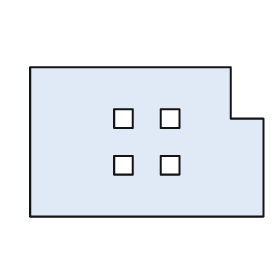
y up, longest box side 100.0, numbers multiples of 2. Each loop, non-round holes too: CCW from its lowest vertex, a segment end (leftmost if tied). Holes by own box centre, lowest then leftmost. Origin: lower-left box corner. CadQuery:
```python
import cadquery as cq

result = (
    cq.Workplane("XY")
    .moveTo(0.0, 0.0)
    .lineTo(100.0, 0.0)
    .lineTo(100.0, 42.0)
    .lineTo(86.0, 42.0)
    .lineTo(86.0, 64.0)
    .lineTo(0.0, 64.0)
    .close()
    .moveTo(36.0, 18.0)
    .lineTo(44.0, 18.0)
    .lineTo(44.0, 26.0)
    .lineTo(36.0, 26.0)
    .close()
    .moveTo(56.0, 18.0)
    .lineTo(64.0, 18.0)
    .lineTo(64.0, 26.0)
    .lineTo(56.0, 26.0)
    .close()
    .moveTo(36.0, 38.0)
    .lineTo(44.0, 38.0)
    .lineTo(44.0, 46.0)
    .lineTo(36.0, 46.0)
    .close()
    .moveTo(56.0, 38.0)
    .lineTo(64.0, 38.0)
    .lineTo(64.0, 46.0)
    .lineTo(56.0, 46.0)
    .close()
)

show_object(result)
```